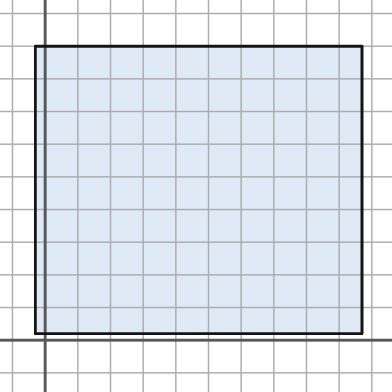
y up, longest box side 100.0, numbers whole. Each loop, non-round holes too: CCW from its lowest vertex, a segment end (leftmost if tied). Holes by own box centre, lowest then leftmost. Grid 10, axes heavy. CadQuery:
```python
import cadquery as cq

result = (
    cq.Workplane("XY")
    .moveTo(-3.0, 2.0)
    .lineTo(97.0, 2.0)
    .lineTo(97.0, 90.0)
    .lineTo(-3.0, 90.0)
    .close()
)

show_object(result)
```